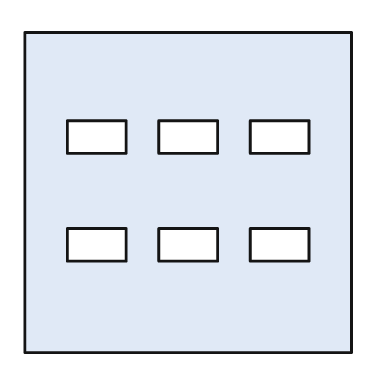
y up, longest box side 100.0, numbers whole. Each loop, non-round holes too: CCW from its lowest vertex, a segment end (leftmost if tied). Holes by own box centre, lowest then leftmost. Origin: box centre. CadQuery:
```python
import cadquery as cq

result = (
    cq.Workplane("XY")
    .moveTo(-50.0, -49.0)
    .lineTo(50.0, -49.0)
    .lineTo(50.0, 49.0)
    .lineTo(-50.0, 49.0)
    .close()
    .moveTo(-37.0, -21.0)
    .lineTo(-19.0, -21.0)
    .lineTo(-19.0, -11.0)
    .lineTo(-37.0, -11.0)
    .close()
    .moveTo(-9.0, -21.0)
    .lineTo(9.0, -21.0)
    .lineTo(9.0, -11.0)
    .lineTo(-9.0, -11.0)
    .close()
    .moveTo(19.0, -21.0)
    .lineTo(37.0, -21.0)
    .lineTo(37.0, -11.0)
    .lineTo(19.0, -11.0)
    .close()
    .moveTo(-37.0, 12.0)
    .lineTo(-19.0, 12.0)
    .lineTo(-19.0, 22.0)
    .lineTo(-37.0, 22.0)
    .close()
    .moveTo(-9.0, 12.0)
    .lineTo(9.0, 12.0)
    .lineTo(9.0, 22.0)
    .lineTo(-9.0, 22.0)
    .close()
    .moveTo(19.0, 12.0)
    .lineTo(37.0, 12.0)
    .lineTo(37.0, 22.0)
    .lineTo(19.0, 22.0)
    .close()
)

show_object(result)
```